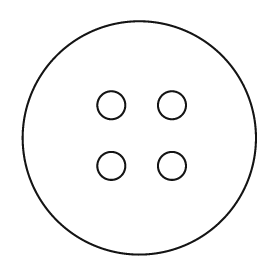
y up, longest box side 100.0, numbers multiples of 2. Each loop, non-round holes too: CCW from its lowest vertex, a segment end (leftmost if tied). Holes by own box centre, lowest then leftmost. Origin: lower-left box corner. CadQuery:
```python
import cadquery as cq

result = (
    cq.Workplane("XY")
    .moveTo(50.0, 50.0)
    .circle(50.0)
    .moveTo(38.0, 38.0)
    .circle(6.0)
    .moveTo(64.0, 38.0)
    .circle(6.0)
    .moveTo(38.0, 64.0)
    .circle(6.0)
    .moveTo(64.0, 64.0)
    .circle(6.0)
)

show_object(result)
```